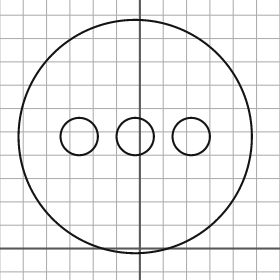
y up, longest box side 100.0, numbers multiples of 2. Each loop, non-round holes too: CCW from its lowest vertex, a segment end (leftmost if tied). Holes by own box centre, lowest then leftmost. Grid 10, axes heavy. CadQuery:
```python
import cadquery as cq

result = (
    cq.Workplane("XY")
    .moveTo(-2.0, 48.0)
    .circle(50.0)
    .moveTo(-26.0, 48.0)
    .circle(8.0)
    .moveTo(-2.0, 48.0)
    .circle(8.0)
    .moveTo(22.0, 48.0)
    .circle(8.0)
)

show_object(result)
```